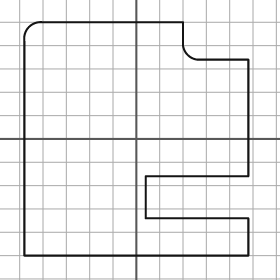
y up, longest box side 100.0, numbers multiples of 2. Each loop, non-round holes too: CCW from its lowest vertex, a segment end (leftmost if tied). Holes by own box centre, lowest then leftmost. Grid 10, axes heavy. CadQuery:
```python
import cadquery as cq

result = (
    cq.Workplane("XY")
    .moveTo(-48.0, -50.0)
    .lineTo(48.0, -50.0)
    .lineTo(48.0, -34.0)
    .lineTo(4.0, -34.0)
    .lineTo(4.0, -16.0)
    .lineTo(48.0, -16.0)
    .lineTo(48.0, 34.0)
    .lineTo(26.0, 34.0)
    .threePointArc((22.0, 36.0), (20.0, 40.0))
    .lineTo(20.0, 50.0)
    .lineTo(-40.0, 50.0)
    .threePointArc((-46.0, 48.0), (-48.0, 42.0))
    .close()
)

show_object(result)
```